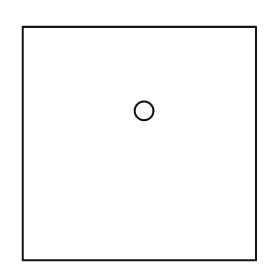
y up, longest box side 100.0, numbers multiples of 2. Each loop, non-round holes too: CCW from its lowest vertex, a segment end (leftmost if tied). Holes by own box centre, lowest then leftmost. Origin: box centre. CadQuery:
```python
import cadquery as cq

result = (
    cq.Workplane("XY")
    .moveTo(-50.0, -50.0)
    .lineTo(50.0, -50.0)
    .lineTo(50.0, 50.0)
    .lineTo(-50.0, 50.0)
    .close()
    .moveTo(2.0, 14.0)
    .circle(4.0)
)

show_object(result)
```